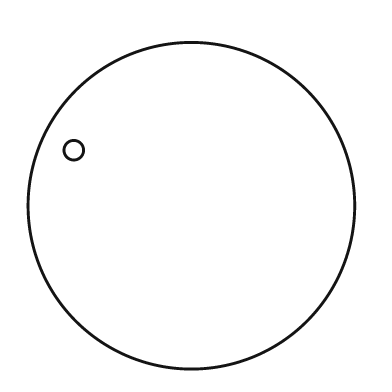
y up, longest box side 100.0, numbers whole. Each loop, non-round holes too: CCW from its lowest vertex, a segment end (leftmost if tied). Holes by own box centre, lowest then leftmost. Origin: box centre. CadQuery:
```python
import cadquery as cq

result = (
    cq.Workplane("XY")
    .moveTo(0.0, 0.0)
    .circle(50.0)
    .moveTo(-36.0, 17.0)
    .circle(3.0)
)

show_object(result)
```